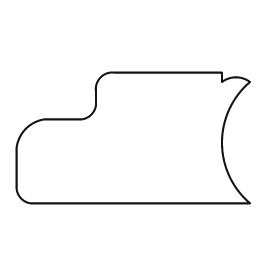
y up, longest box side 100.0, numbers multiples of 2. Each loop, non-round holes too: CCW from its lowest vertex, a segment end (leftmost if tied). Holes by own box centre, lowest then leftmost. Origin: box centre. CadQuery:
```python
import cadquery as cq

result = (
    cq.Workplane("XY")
    .moveTo(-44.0, -28.0)
    .lineTo(50.0, -28.0)
    .threePointArc((38.0, -2.0), (50.0, 24.0))
    .threePointArc((44.0, 26.0), (38.0, 24.0))
    .lineTo(38.0, 28.0)
    .lineTo(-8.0, 28.0)
    .threePointArc((-14.0, 26.0), (-16.0, 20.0))
    .lineTo(-16.0, 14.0)
    .threePointArc((-18.0, 10.0), (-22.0, 8.0))
    .lineTo(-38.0, 8.0)
    .threePointArc((-46.0, 4.0), (-50.0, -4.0))
    .lineTo(-50.0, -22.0)
    .threePointArc((-48.0, -26.0), (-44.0, -28.0))
    .close()
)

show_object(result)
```